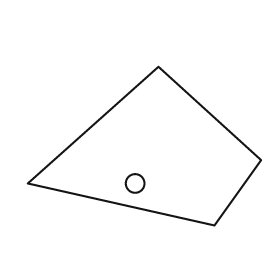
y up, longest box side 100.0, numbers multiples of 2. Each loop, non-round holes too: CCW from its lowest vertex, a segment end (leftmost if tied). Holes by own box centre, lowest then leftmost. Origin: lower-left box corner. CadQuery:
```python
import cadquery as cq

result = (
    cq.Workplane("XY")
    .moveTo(80.0, 0.0)
    .lineTo(100.0, 28.0)
    .lineTo(56.0, 68.0)
    .lineTo(0.0, 18.0)
    .close()
    .moveTo(46.0, 18.0)
    .circle(4.0)
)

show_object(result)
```